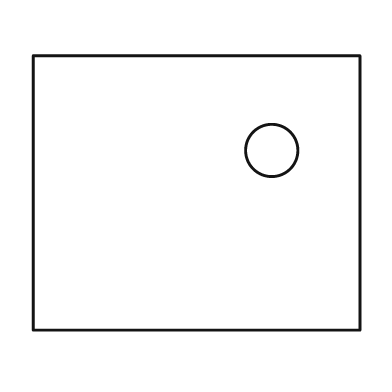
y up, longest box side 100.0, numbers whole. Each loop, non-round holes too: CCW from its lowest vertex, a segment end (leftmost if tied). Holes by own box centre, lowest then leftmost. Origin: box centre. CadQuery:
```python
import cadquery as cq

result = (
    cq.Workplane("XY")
    .moveTo(-50.0, -42.0)
    .lineTo(50.0, -42.0)
    .lineTo(50.0, 42.0)
    .lineTo(-50.0, 42.0)
    .close()
    .moveTo(23.0, 13.0)
    .circle(8.0)
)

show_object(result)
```